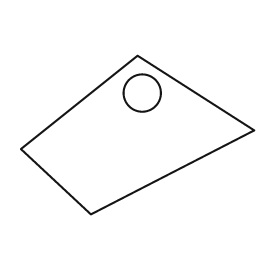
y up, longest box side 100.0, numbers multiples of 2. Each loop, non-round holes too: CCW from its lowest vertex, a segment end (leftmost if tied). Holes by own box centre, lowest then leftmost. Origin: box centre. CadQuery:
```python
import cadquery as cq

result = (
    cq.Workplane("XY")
    .moveTo(-20.0, -34.0)
    .lineTo(50.0, 2.0)
    .lineTo(0.0, 34.0)
    .lineTo(-50.0, -6.0)
    .close()
    .moveTo(2.0, 18.0)
    .circle(8.0)
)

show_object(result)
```